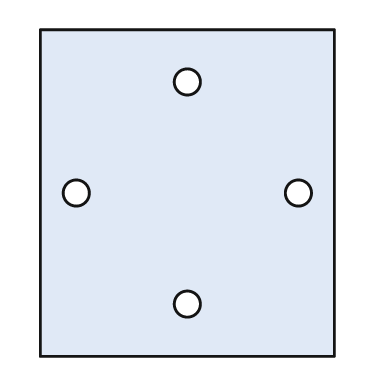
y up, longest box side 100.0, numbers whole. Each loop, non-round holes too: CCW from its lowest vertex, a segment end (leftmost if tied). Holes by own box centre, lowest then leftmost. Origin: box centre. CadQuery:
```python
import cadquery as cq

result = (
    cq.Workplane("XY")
    .moveTo(-45.0, -50.0)
    .lineTo(45.0, -50.0)
    .lineTo(45.0, 50.0)
    .lineTo(-45.0, 50.0)
    .close()
    .moveTo(0.0, -34.0)
    .circle(4.0)
    .moveTo(-34.0, 0.0)
    .circle(4.0)
    .moveTo(34.0, 0.0)
    .circle(4.0)
    .moveTo(0.0, 34.0)
    .circle(4.0)
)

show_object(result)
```